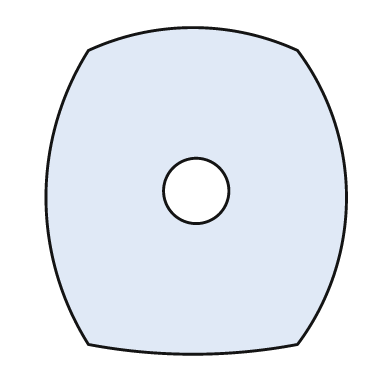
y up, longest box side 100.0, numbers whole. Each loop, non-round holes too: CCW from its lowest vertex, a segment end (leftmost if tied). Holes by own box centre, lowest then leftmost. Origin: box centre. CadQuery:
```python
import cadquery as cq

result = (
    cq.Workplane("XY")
    .moveTo(-33.0, -47.0)
    .threePointArc((-1.0, -50.0), (31.0, -47.0))
    .threePointArc((46.0, -2.0), (31.0, 43.0))
    .threePointArc((-1.0, 50.0), (-33.0, 43.0))
    .threePointArc((-46.0, -2.0), (-33.0, -47.0))
    .close()
    .moveTo(0.0, 0.0)
    .circle(10.0)
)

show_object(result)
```